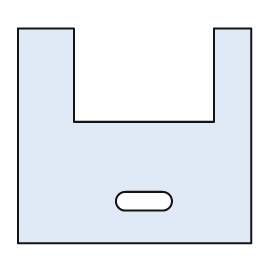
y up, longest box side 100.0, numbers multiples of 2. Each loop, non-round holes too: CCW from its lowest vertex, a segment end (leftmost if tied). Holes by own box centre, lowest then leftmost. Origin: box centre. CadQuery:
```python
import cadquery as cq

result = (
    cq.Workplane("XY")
    .moveTo(-50.0, -46.0)
    .lineTo(50.0, -46.0)
    .lineTo(50.0, 46.0)
    .lineTo(34.0, 46.0)
    .lineTo(34.0, 6.0)
    .lineTo(-26.0, 6.0)
    .lineTo(-26.0, 46.0)
    .lineTo(-50.0, 46.0)
    .close()
    .moveTo(-4.0, -32.0)
    .lineTo(12.0, -32.0)
    .threePointArc((16.0, -28.0), (12.0, -24.0))
    .lineTo(-4.0, -24.0)
    .threePointArc((-8.0, -28.0), (-4.0, -32.0))
    .close()
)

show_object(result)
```